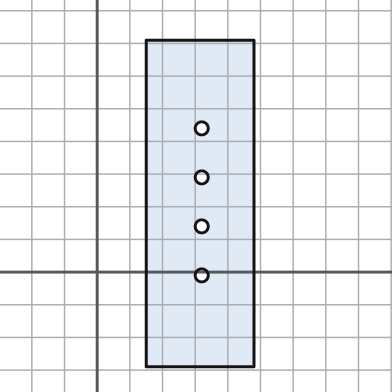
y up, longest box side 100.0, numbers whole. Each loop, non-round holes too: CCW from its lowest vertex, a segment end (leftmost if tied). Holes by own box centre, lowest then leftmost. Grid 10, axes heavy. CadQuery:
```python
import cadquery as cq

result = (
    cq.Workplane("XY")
    .moveTo(15.0, -29.0)
    .lineTo(48.0, -29.0)
    .lineTo(48.0, 71.0)
    .lineTo(15.0, 71.0)
    .close()
    .moveTo(32.0, -1.0)
    .circle(2.0)
    .moveTo(32.0, 14.0)
    .circle(2.0)
    .moveTo(32.0, 29.0)
    .circle(2.0)
    .moveTo(32.0, 44.0)
    .circle(2.0)
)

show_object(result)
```